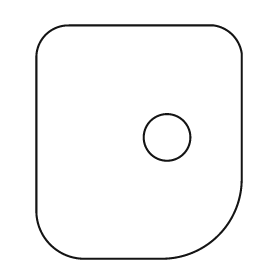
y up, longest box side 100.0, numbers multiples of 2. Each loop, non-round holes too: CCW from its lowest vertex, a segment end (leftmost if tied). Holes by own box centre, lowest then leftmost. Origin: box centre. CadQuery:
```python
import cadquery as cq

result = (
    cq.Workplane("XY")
    .moveTo(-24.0, -50.0)
    .lineTo(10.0, -50.0)
    .threePointArc((34.0, -40.0), (44.0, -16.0))
    .lineTo(44.0, 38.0)
    .threePointArc((40.0, 46.0), (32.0, 50.0))
    .lineTo(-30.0, 50.0)
    .threePointArc((-40.0, 46.0), (-44.0, 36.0))
    .lineTo(-44.0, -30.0)
    .threePointArc((-38.0, -44.0), (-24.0, -50.0))
    .close()
    .moveTo(12.0, 2.0)
    .circle(10.0)
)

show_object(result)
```